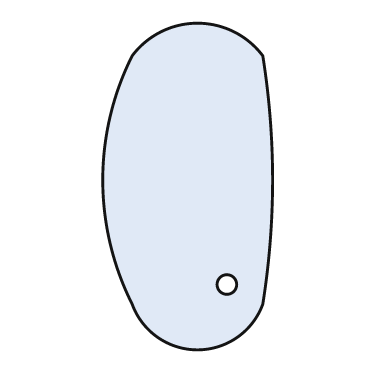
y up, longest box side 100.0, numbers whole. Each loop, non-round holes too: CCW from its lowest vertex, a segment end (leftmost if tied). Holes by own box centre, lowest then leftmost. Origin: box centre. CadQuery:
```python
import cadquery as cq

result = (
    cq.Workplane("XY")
    .moveTo(-17.0, -36.0)
    .threePointArc((3.0, -50.0), (23.0, -36.0))
    .threePointArc((26.0, 2.0), (23.0, 40.0))
    .threePointArc((3.0, 50.0), (-17.0, 40.0))
    .threePointArc((-26.0, 2.0), (-17.0, -36.0))
    .close()
    .moveTo(12.0, -30.0)
    .circle(3.0)
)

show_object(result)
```